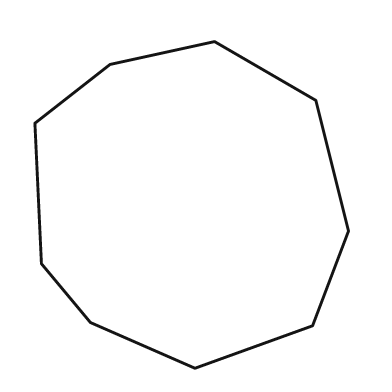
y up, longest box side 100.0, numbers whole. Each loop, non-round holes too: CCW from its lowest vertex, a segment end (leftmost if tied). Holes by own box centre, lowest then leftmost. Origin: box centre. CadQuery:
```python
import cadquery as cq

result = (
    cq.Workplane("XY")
    .moveTo(1.0, -50.0)
    .lineTo(37.0, -37.0)
    .lineTo(48.0, -8.0)
    .lineTo(38.0, 32.0)
    .lineTo(7.0, 50.0)
    .lineTo(-25.0, 43.0)
    .lineTo(-48.0, 25.0)
    .lineTo(-46.0, -18.0)
    .lineTo(-31.0, -36.0)
    .close()
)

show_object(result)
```